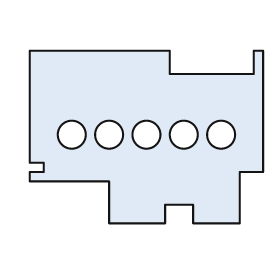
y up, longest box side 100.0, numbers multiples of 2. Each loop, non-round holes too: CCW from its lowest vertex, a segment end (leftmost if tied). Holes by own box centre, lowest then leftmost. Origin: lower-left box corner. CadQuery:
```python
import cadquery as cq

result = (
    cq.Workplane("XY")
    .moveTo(34.0, 0.0)
    .lineTo(58.0, 0.0)
    .lineTo(58.0, 8.0)
    .lineTo(70.0, 8.0)
    .lineTo(70.0, 0.0)
    .lineTo(90.0, 0.0)
    .lineTo(90.0, 22.0)
    .lineTo(100.0, 22.0)
    .lineTo(100.0, 74.0)
    .lineTo(96.0, 74.0)
    .lineTo(96.0, 64.0)
    .lineTo(60.0, 64.0)
    .lineTo(60.0, 74.0)
    .lineTo(0.0, 74.0)
    .lineTo(0.0, 26.0)
    .lineTo(6.0, 26.0)
    .lineTo(6.0, 22.0)
    .lineTo(0.0, 22.0)
    .lineTo(0.0, 18.0)
    .lineTo(34.0, 18.0)
    .close()
    .moveTo(18.0, 38.0)
    .circle(6.0)
    .moveTo(34.0, 38.0)
    .circle(6.0)
    .moveTo(50.0, 38.0)
    .circle(6.0)
    .moveTo(66.0, 38.0)
    .circle(6.0)
    .moveTo(82.0, 38.0)
    .circle(6.0)
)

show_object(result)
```